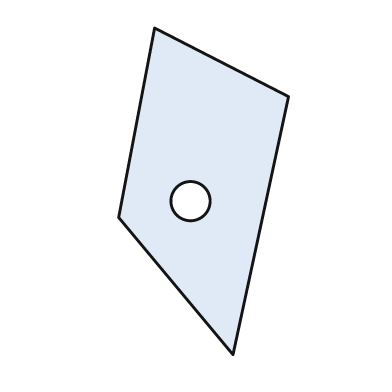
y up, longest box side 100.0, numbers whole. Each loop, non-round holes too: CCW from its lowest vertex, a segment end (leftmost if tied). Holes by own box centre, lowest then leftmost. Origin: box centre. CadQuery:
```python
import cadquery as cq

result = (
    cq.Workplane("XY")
    .moveTo(9.0, -50.0)
    .lineTo(26.0, 29.0)
    .lineTo(-15.0, 50.0)
    .lineTo(-26.0, -8.0)
    .close()
    .moveTo(-4.0, -3.0)
    .circle(6.0)
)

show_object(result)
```